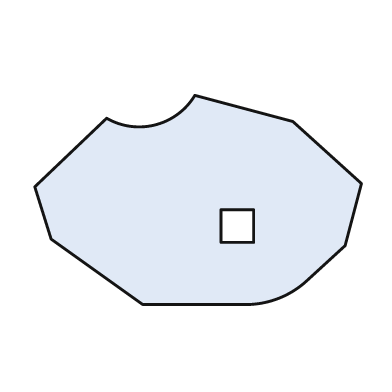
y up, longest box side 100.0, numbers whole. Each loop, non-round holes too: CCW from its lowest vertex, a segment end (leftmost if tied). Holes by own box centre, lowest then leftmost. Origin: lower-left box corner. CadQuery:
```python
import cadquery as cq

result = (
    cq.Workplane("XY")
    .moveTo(33.0, 0.0)
    .lineTo(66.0, 0.0)
    .threePointArc((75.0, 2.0), (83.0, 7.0))
    .lineTo(95.0, 18.0)
    .lineTo(100.0, 37.0)
    .lineTo(79.0, 56.0)
    .lineTo(49.0, 64.0)
    .threePointArc((37.0, 55.0), (22.0, 57.0))
    .lineTo(0.0, 36.0)
    .lineTo(5.0, 20.0)
    .close()
    .moveTo(57.0, 19.0)
    .lineTo(67.0, 19.0)
    .lineTo(67.0, 29.0)
    .lineTo(57.0, 29.0)
    .close()
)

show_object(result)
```